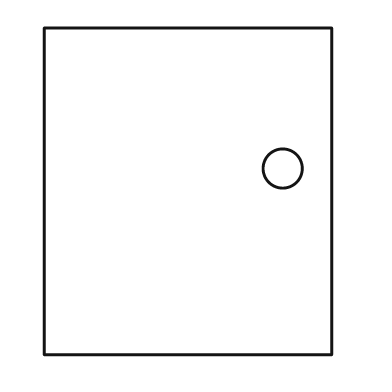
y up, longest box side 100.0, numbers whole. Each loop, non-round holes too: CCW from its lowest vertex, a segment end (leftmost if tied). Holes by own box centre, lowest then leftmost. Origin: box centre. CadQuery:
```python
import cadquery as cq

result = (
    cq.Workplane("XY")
    .moveTo(-44.0, -50.0)
    .lineTo(44.0, -50.0)
    .lineTo(44.0, 50.0)
    .lineTo(-44.0, 50.0)
    .close()
    .moveTo(29.0, 7.0)
    .circle(6.0)
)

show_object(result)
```